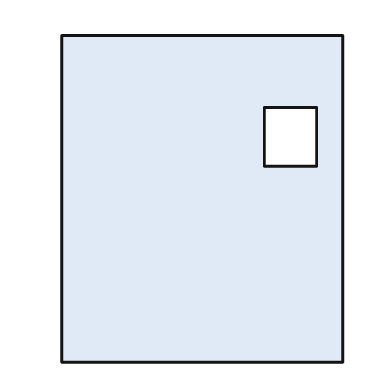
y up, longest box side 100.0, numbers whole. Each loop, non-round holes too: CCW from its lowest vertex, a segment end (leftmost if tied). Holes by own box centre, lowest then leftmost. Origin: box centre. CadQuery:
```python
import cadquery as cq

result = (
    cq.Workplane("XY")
    .moveTo(-43.0, -50.0)
    .lineTo(43.0, -50.0)
    .lineTo(43.0, 50.0)
    .lineTo(-43.0, 50.0)
    .close()
    .moveTo(19.0, 10.0)
    .lineTo(35.0, 10.0)
    .lineTo(35.0, 28.0)
    .lineTo(19.0, 28.0)
    .close()
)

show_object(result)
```